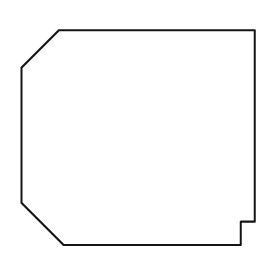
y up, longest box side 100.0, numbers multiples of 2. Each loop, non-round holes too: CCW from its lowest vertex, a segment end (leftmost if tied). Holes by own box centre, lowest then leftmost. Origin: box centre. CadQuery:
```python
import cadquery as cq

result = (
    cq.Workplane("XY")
    .moveTo(-32.0, -46.0)
    .lineTo(44.0, -46.0)
    .lineTo(44.0, -36.0)
    .lineTo(50.0, -36.0)
    .lineTo(50.0, 46.0)
    .lineTo(-34.0, 46.0)
    .lineTo(-50.0, 30.0)
    .lineTo(-50.0, -28.0)
    .close()
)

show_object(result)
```